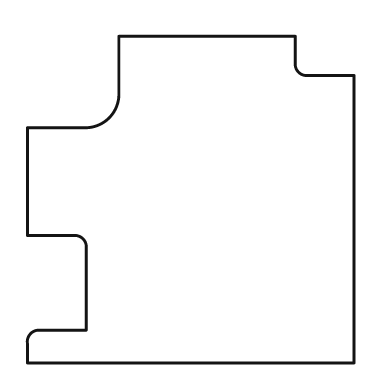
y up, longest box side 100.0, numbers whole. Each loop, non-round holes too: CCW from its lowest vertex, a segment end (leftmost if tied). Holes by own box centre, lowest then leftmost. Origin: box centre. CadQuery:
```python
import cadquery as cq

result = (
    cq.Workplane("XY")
    .moveTo(-50.0, -50.0)
    .lineTo(50.0, -50.0)
    .lineTo(50.0, 38.0)
    .lineTo(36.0, 38.0)
    .threePointArc((33.0, 39.0), (32.0, 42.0))
    .lineTo(32.0, 50.0)
    .lineTo(-22.0, 50.0)
    .lineTo(-22.0, 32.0)
    .threePointArc((-25.0, 25.0), (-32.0, 22.0))
    .lineTo(-50.0, 22.0)
    .lineTo(-50.0, -11.0)
    .lineTo(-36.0, -11.0)
    .threePointArc((-33.0, -12.0), (-32.0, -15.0))
    .lineTo(-32.0, -40.0)
    .lineTo(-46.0, -40.0)
    .threePointArc((-49.0, -41.0), (-50.0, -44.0))
    .close()
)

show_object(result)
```